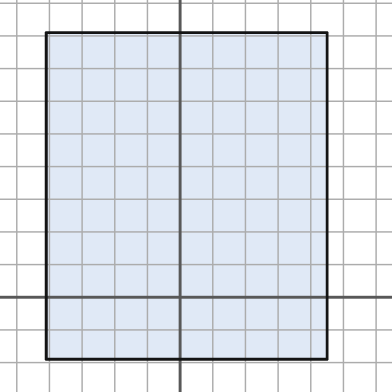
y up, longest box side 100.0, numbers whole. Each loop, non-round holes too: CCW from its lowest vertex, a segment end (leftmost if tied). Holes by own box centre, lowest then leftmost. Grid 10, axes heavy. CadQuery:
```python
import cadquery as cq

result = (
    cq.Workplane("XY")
    .moveTo(-41.0, -19.0)
    .lineTo(45.0, -19.0)
    .lineTo(45.0, 81.0)
    .lineTo(-41.0, 81.0)
    .close()
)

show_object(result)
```